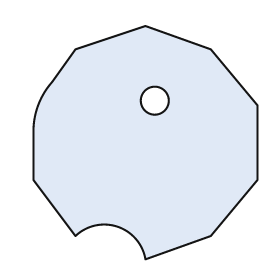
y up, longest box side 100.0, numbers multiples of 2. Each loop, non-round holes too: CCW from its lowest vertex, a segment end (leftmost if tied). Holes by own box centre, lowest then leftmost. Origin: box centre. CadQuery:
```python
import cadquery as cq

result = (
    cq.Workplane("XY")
    .moveTo(0.0, -50.0)
    .lineTo(28.0, -40.0)
    .lineTo(48.0, -16.0)
    .lineTo(48.0, 16.0)
    .lineTo(28.0, 40.0)
    .lineTo(0.0, 50.0)
    .lineTo(-30.0, 40.0)
    .lineTo(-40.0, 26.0)
    .threePointArc((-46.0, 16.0), (-48.0, 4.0))
    .lineTo(-48.0, -16.0)
    .lineTo(-30.0, -40.0)
    .threePointArc((-12.0, -36.0), (0.0, -50.0))
    .close()
    .moveTo(4.0, 18.0)
    .circle(6.0)
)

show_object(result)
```